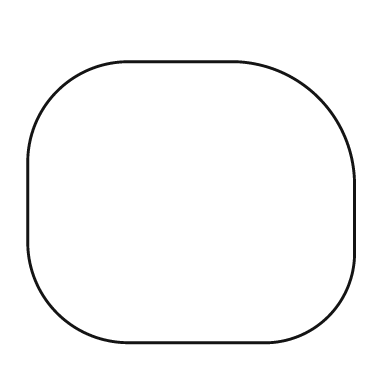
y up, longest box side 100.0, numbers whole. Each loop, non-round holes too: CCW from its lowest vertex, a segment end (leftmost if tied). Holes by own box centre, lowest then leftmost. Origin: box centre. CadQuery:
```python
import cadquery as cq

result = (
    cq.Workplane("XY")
    .moveTo(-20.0, -43.0)
    .lineTo(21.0, -43.0)
    .threePointArc((42.0, -35.0), (50.0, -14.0))
    .lineTo(50.0, 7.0)
    .threePointArc((39.0, 32.0), (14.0, 43.0))
    .lineTo(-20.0, 43.0)
    .threePointArc((-41.0, 34.0), (-50.0, 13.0))
    .lineTo(-50.0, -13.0)
    .threePointArc((-41.0, -34.0), (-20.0, -43.0))
    .close()
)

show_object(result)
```